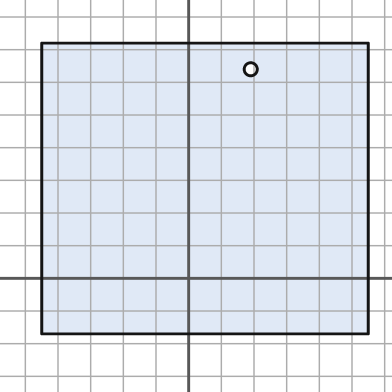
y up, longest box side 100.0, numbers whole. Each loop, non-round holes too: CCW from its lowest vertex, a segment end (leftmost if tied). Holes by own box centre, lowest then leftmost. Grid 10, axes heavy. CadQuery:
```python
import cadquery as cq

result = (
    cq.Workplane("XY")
    .moveTo(-45.0, -17.0)
    .lineTo(55.0, -17.0)
    .lineTo(55.0, 72.0)
    .lineTo(-45.0, 72.0)
    .close()
    .moveTo(19.0, 64.0)
    .circle(2.0)
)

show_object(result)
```